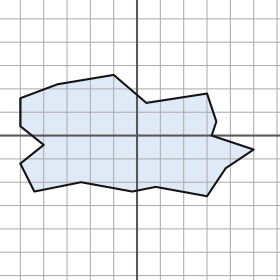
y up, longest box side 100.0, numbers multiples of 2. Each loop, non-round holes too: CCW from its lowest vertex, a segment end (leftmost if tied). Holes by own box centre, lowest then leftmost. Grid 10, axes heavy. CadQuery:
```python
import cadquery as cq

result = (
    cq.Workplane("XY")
    .moveTo(30.0, -26.0)
    .lineTo(38.0, -14.0)
    .lineTo(50.0, -6.0)
    .lineTo(32.0, 0.0)
    .lineTo(34.0, 6.0)
    .lineTo(30.0, 18.0)
    .lineTo(4.0, 14.0)
    .lineTo(-10.0, 26.0)
    .lineTo(-34.0, 22.0)
    .lineTo(-50.0, 16.0)
    .lineTo(-50.0, 4.0)
    .lineTo(-40.0, -4.0)
    .lineTo(-50.0, -12.0)
    .lineTo(-44.0, -24.0)
    .lineTo(-24.0, -20.0)
    .lineTo(-2.0, -24.0)
    .lineTo(8.0, -22.0)
    .close()
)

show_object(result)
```